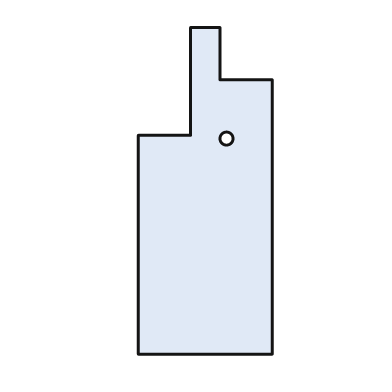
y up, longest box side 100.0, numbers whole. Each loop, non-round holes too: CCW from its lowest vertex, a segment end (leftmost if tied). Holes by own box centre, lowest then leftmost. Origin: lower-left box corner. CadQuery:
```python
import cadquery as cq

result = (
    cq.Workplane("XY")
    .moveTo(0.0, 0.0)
    .lineTo(41.0, 0.0)
    .lineTo(41.0, 84.0)
    .lineTo(25.0, 84.0)
    .lineTo(25.0, 100.0)
    .lineTo(16.0, 100.0)
    .lineTo(16.0, 67.0)
    .lineTo(0.0, 67.0)
    .close()
    .moveTo(27.0, 66.0)
    .circle(2.0)
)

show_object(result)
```